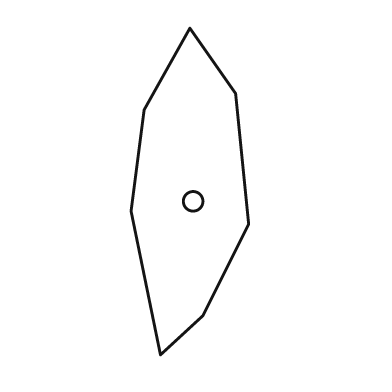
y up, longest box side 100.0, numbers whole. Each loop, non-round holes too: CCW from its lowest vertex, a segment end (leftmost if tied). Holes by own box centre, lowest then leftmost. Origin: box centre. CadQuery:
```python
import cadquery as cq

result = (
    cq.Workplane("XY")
    .moveTo(-9.0, -50.0)
    .lineTo(4.0, -38.0)
    .lineTo(18.0, -10.0)
    .lineTo(14.0, 30.0)
    .lineTo(0.0, 50.0)
    .lineTo(-14.0, 25.0)
    .lineTo(-18.0, -6.0)
    .close()
    .moveTo(1.0, -3.0)
    .circle(3.0)
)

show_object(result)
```